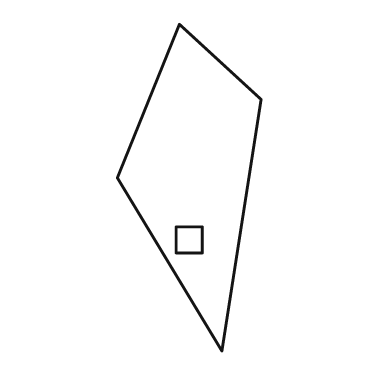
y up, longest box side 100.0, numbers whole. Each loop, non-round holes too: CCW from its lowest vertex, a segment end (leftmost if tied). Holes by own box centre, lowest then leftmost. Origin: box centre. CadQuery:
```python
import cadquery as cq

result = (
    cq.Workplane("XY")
    .moveTo(10.0, -50.0)
    .lineTo(22.0, 27.0)
    .lineTo(-3.0, 50.0)
    .lineTo(-22.0, 3.0)
    .close()
    .moveTo(-4.0, -20.0)
    .lineTo(4.0, -20.0)
    .lineTo(4.0, -12.0)
    .lineTo(-4.0, -12.0)
    .close()
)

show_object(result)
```